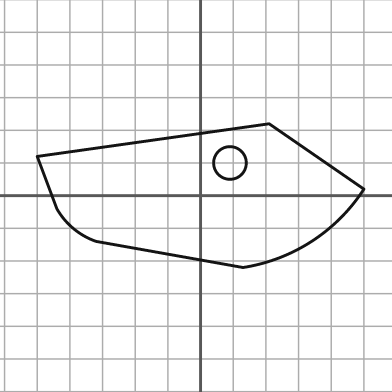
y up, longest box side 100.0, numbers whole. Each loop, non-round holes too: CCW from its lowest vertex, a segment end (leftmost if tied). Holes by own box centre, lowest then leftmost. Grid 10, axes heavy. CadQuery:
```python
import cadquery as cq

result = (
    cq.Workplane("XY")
    .moveTo(13.0, -22.0)
    .threePointArc((34.0, -14.0), (50.0, 2.0))
    .lineTo(21.0, 22.0)
    .lineTo(-50.0, 12.0)
    .lineTo(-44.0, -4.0)
    .threePointArc((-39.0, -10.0), (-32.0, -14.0))
    .close()
    .moveTo(9.0, 10.0)
    .circle(5.0)
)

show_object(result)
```